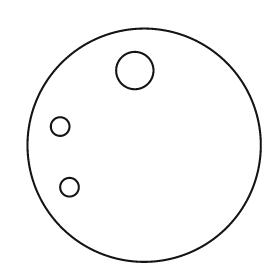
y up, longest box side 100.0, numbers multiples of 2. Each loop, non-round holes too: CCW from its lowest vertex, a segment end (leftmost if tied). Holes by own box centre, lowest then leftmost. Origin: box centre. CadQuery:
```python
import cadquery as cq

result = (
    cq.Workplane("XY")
    .moveTo(0.0, 0.0)
    .circle(50.0)
    .moveTo(-32.0, -18.0)
    .circle(4.0)
    .moveTo(-36.0, 8.0)
    .circle(4.0)
    .moveTo(-4.0, 32.0)
    .circle(8.0)
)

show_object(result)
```